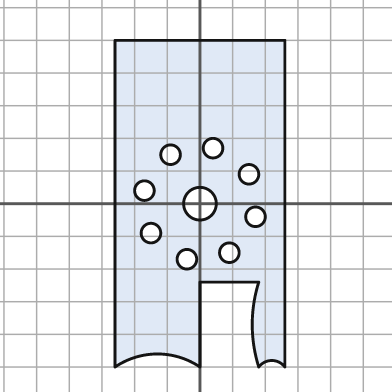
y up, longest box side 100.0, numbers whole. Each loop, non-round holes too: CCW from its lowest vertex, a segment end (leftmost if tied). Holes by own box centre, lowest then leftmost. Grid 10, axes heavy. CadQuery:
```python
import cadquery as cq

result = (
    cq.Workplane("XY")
    .moveTo(-26.0, -50.0)
    .threePointArc((-13.0, -46.0), (0.0, -50.0))
    .lineTo(0.0, -24.0)
    .lineTo(18.0, -24.0)
    .threePointArc((16.0, -37.0), (18.0, -50.0))
    .threePointArc((22.0, -48.0), (26.0, -50.0))
    .lineTo(26.0, 50.0)
    .lineTo(-26.0, 50.0)
    .close()
    .moveTo(-4.0, -17.0)
    .circle(3.0)
    .moveTo(9.0, -15.0)
    .circle(3.0)
    .moveTo(-15.0, -9.0)
    .circle(3.0)
    .moveTo(17.0, -4.0)
    .circle(3.0)
    .moveTo(0.0, 0.0)
    .circle(5.0)
    .moveTo(-17.0, 4.0)
    .circle(3.0)
    .moveTo(15.0, 9.0)
    .circle(3.0)
    .moveTo(-9.0, 15.0)
    .circle(3.0)
    .moveTo(4.0, 17.0)
    .circle(3.0)
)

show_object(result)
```